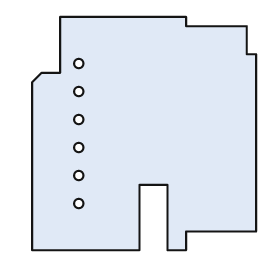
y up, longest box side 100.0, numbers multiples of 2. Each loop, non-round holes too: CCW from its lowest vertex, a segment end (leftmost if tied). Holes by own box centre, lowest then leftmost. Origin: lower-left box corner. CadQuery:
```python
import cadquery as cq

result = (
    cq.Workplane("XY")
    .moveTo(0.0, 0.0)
    .lineTo(46.0, 0.0)
    .lineTo(46.0, 28.0)
    .lineTo(58.0, 28.0)
    .lineTo(58.0, 0.0)
    .lineTo(66.0, 0.0)
    .lineTo(66.0, 8.0)
    .lineTo(96.0, 8.0)
    .lineTo(96.0, 84.0)
    .lineTo(92.0, 84.0)
    .lineTo(92.0, 96.0)
    .lineTo(66.0, 96.0)
    .lineTo(66.0, 100.0)
    .lineTo(12.0, 100.0)
    .lineTo(12.0, 76.0)
    .lineTo(4.0, 76.0)
    .lineTo(0.0, 72.0)
    .close()
    .moveTo(20.0, 20.0)
    .circle(2.0)
    .moveTo(20.0, 32.0)
    .circle(2.0)
    .moveTo(20.0, 44.0)
    .circle(2.0)
    .moveTo(20.0, 56.0)
    .circle(2.0)
    .moveTo(20.0, 68.0)
    .circle(2.0)
    .moveTo(20.0, 80.0)
    .circle(2.0)
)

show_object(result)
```